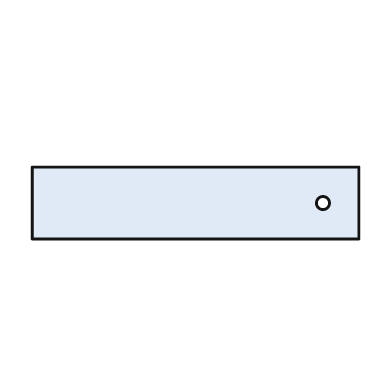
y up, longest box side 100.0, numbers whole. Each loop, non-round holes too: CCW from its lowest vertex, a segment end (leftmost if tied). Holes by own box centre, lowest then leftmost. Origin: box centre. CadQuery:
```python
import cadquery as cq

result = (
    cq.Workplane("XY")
    .moveTo(-50.0, -11.0)
    .lineTo(50.0, -11.0)
    .lineTo(50.0, 11.0)
    .lineTo(-50.0, 11.0)
    .close()
    .moveTo(39.0, 0.0)
    .circle(2.0)
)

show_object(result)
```